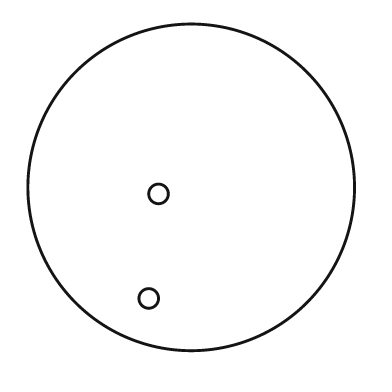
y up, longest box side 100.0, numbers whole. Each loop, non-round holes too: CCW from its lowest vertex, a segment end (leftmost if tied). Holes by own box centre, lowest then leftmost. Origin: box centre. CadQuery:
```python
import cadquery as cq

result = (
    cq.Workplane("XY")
    .moveTo(0.0, 0.0)
    .circle(50.0)
    .moveTo(-13.0, -34.0)
    .circle(3.0)
    .moveTo(-10.0, -2.0)
    .circle(3.0)
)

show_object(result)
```